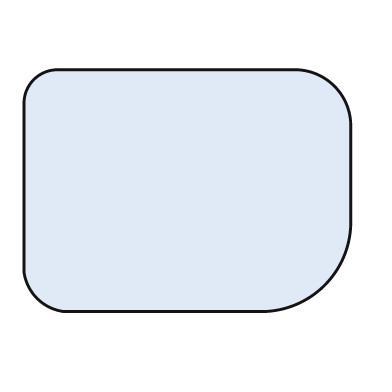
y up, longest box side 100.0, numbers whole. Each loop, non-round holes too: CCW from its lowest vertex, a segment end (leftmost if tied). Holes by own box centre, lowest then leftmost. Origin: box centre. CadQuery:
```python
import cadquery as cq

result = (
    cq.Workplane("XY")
    .moveTo(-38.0, -37.0)
    .lineTo(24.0, -37.0)
    .threePointArc((42.0, -29.0), (50.0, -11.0))
    .lineTo(50.0, 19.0)
    .threePointArc((45.0, 32.0), (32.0, 37.0))
    .lineTo(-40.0, 37.0)
    .threePointArc((-47.0, 34.0), (-50.0, 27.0))
    .lineTo(-50.0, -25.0)
    .threePointArc((-46.0, -33.0), (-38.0, -37.0))
    .close()
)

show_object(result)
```